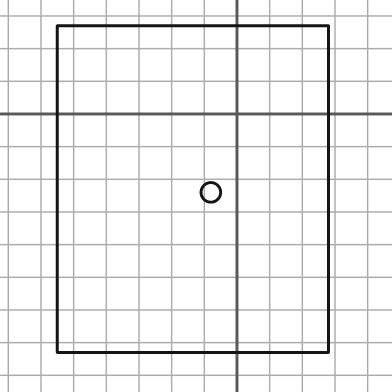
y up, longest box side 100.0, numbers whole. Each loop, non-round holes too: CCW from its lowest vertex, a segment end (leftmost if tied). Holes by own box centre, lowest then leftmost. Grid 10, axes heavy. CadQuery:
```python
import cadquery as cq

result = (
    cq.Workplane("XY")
    .moveTo(-55.0, -73.0)
    .lineTo(28.0, -73.0)
    .lineTo(28.0, 27.0)
    .lineTo(-55.0, 27.0)
    .close()
    .moveTo(-8.0, -24.0)
    .circle(3.0)
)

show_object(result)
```